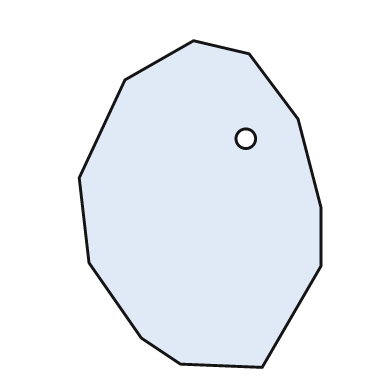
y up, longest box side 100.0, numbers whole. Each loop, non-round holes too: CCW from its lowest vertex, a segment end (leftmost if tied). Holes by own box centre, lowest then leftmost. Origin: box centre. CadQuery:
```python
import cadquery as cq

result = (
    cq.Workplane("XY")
    .moveTo(19.0, -50.0)
    .lineTo(37.0, -19.0)
    .lineTo(37.0, -1.0)
    .lineTo(30.0, 26.0)
    .lineTo(15.0, 46.0)
    .lineTo(-2.0, 50.0)
    .lineTo(-23.0, 38.0)
    .lineTo(-37.0, 8.0)
    .lineTo(-34.0, -18.0)
    .lineTo(-18.0, -41.0)
    .lineTo(-6.0, -49.0)
    .close()
    .moveTo(14.0, 20.0)
    .circle(3.0)
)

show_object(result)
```